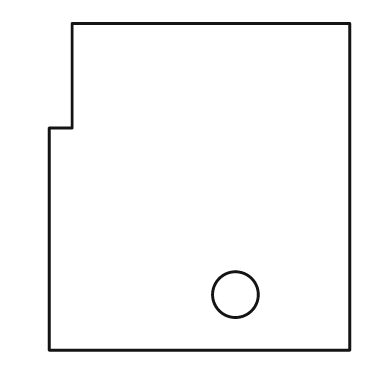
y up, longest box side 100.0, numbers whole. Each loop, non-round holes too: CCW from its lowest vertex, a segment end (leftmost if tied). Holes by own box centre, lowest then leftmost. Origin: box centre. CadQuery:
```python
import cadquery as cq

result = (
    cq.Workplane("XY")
    .moveTo(-46.0, -50.0)
    .lineTo(46.0, -50.0)
    .lineTo(46.0, 50.0)
    .lineTo(-39.0, 50.0)
    .lineTo(-39.0, 18.0)
    .lineTo(-46.0, 18.0)
    .close()
    .moveTo(11.0, -33.0)
    .circle(7.0)
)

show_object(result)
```